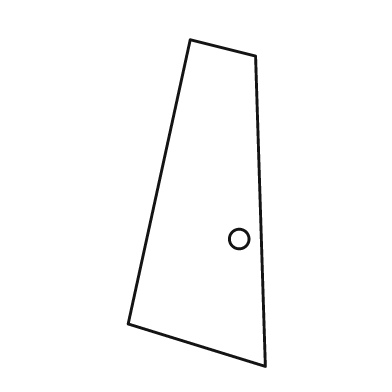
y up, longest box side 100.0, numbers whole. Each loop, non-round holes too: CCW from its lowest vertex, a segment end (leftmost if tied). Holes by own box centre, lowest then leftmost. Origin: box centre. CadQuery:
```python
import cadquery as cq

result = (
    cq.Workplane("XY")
    .moveTo(21.0, -50.0)
    .lineTo(18.0, 45.0)
    .lineTo(-2.0, 50.0)
    .lineTo(-21.0, -37.0)
    .close()
    .moveTo(13.0, -11.0)
    .circle(3.0)
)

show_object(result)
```